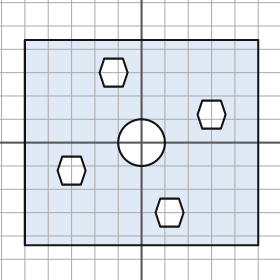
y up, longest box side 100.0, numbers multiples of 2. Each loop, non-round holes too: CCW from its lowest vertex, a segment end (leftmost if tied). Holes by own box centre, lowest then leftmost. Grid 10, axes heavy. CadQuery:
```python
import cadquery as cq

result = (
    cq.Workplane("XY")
    .moveTo(-50.0, -44.0)
    .lineTo(50.0, -44.0)
    .lineTo(50.0, 44.0)
    .lineTo(-50.0, 44.0)
    .close()
    .moveTo(8.0, -36.0)
    .lineTo(16.0, -36.0)
    .lineTo(18.0, -30.0)
    .lineTo(16.0, -24.0)
    .lineTo(8.0, -24.0)
    .lineTo(6.0, -30.0)
    .close()
    .moveTo(-34.0, -18.0)
    .lineTo(-26.0, -18.0)
    .lineTo(-24.0, -12.0)
    .lineTo(-26.0, -6.0)
    .lineTo(-34.0, -6.0)
    .lineTo(-36.0, -12.0)
    .close()
    .moveTo(0.0, 0.0)
    .circle(10.0)
    .moveTo(26.0, 6.0)
    .lineTo(34.0, 6.0)
    .lineTo(36.0, 12.0)
    .lineTo(34.0, 18.0)
    .lineTo(26.0, 18.0)
    .lineTo(24.0, 12.0)
    .close()
    .moveTo(-16.0, 24.0)
    .lineTo(-8.0, 24.0)
    .lineTo(-6.0, 30.0)
    .lineTo(-8.0, 36.0)
    .lineTo(-16.0, 36.0)
    .lineTo(-18.0, 30.0)
    .close()
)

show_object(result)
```